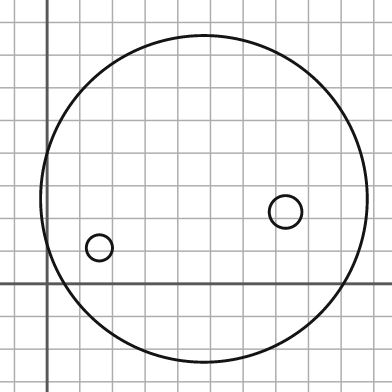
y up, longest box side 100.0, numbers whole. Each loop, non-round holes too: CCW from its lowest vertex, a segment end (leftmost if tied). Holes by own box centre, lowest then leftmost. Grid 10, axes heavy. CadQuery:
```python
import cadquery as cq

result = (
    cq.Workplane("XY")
    .moveTo(48.0, 26.0)
    .circle(50.0)
    .moveTo(16.0, 11.0)
    .circle(4.0)
    .moveTo(73.0, 22.0)
    .circle(5.0)
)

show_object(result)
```